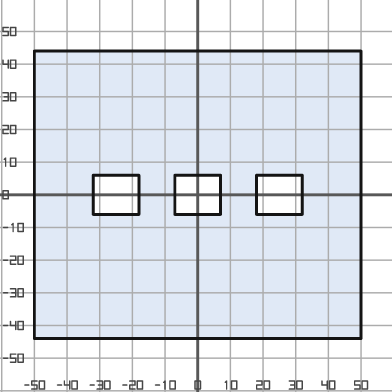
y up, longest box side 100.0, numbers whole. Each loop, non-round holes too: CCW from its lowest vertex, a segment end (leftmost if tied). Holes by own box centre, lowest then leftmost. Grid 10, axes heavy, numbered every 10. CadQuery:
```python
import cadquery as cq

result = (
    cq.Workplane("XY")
    .moveTo(-50.0, -44.0)
    .lineTo(50.0, -44.0)
    .lineTo(50.0, 44.0)
    .lineTo(-50.0, 44.0)
    .close()
    .moveTo(-32.0, -6.0)
    .lineTo(-18.0, -6.0)
    .lineTo(-18.0, 6.0)
    .lineTo(-32.0, 6.0)
    .close()
    .moveTo(-7.0, -6.0)
    .lineTo(7.0, -6.0)
    .lineTo(7.0, 6.0)
    .lineTo(-7.0, 6.0)
    .close()
    .moveTo(18.0, -6.0)
    .lineTo(32.0, -6.0)
    .lineTo(32.0, 6.0)
    .lineTo(18.0, 6.0)
    .close()
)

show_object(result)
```